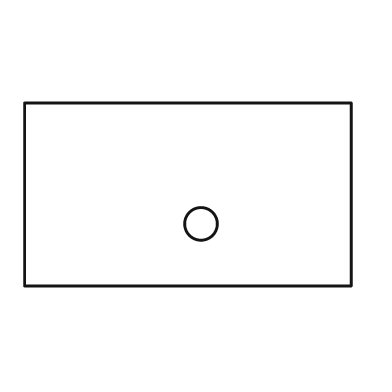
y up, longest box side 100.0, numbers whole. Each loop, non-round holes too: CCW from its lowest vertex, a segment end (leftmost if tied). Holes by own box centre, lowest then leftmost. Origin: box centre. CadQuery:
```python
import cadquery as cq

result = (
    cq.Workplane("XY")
    .moveTo(-50.0, -28.0)
    .lineTo(50.0, -28.0)
    .lineTo(50.0, 28.0)
    .lineTo(-50.0, 28.0)
    .close()
    .moveTo(4.0, -9.0)
    .circle(5.0)
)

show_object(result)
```